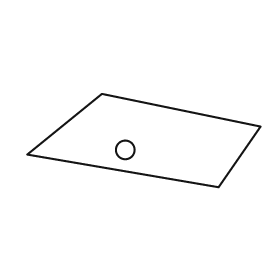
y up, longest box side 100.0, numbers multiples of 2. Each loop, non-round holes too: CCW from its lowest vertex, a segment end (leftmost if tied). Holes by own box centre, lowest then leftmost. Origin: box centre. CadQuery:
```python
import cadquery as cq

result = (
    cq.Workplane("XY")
    .moveTo(32.0, -20.0)
    .lineTo(50.0, 6.0)
    .lineTo(-18.0, 20.0)
    .lineTo(-50.0, -6.0)
    .close()
    .moveTo(-8.0, -4.0)
    .circle(4.0)
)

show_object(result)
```